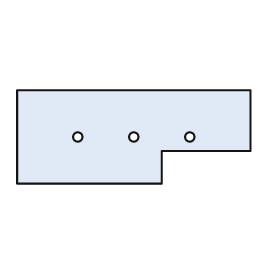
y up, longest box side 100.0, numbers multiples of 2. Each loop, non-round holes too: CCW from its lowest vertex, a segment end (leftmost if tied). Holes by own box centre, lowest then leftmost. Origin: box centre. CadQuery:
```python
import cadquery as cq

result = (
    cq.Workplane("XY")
    .moveTo(-50.0, -20.0)
    .lineTo(12.0, -20.0)
    .lineTo(12.0, -6.0)
    .lineTo(50.0, -6.0)
    .lineTo(50.0, 20.0)
    .lineTo(-50.0, 20.0)
    .close()
    .moveTo(-24.0, 0.0)
    .circle(2.0)
    .moveTo(0.0, 0.0)
    .circle(2.0)
    .moveTo(24.0, 0.0)
    .circle(2.0)
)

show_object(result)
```